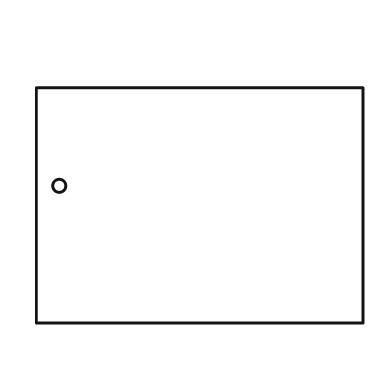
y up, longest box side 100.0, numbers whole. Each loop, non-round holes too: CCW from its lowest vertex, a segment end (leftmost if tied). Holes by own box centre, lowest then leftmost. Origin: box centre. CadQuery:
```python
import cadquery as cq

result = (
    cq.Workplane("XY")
    .moveTo(-50.0, -36.0)
    .lineTo(50.0, -36.0)
    .lineTo(50.0, 36.0)
    .lineTo(-50.0, 36.0)
    .close()
    .moveTo(-43.0, 6.0)
    .circle(2.0)
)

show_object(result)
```